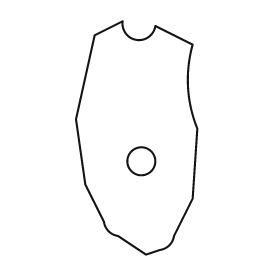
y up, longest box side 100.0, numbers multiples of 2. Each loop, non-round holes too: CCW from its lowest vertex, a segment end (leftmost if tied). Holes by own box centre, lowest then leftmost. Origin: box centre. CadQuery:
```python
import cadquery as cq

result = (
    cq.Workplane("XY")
    .moveTo(4.0, -50.0)
    .lineTo(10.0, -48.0)
    .threePointArc((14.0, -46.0), (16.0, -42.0))
    .lineTo(24.0, -26.0)
    .lineTo(26.0, 4.0)
    .threePointArc((22.0, 22.0), (24.0, 40.0))
    .lineTo(8.0, 48.0)
    .threePointArc((0.0, 42.0), (-6.0, 50.0))
    .lineTo(-18.0, 44.0)
    .lineTo(-26.0, 8.0)
    .lineTo(-22.0, -20.0)
    .lineTo(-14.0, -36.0)
    .threePointArc((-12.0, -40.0), (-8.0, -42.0))
    .close()
    .moveTo(2.0, -10.0)
    .circle(6.0)
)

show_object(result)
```